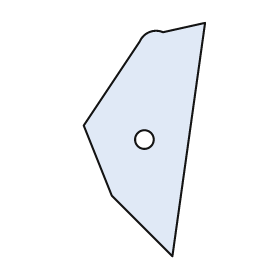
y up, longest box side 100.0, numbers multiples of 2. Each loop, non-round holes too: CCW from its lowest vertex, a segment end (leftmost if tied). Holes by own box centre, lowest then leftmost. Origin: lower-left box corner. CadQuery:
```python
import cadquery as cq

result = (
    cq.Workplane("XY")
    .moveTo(38.0, 0.0)
    .lineTo(52.0, 100.0)
    .lineTo(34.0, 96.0)
    .threePointArc((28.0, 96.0), (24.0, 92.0))
    .lineTo(0.0, 56.0)
    .lineTo(12.0, 26.0)
    .close()
    .moveTo(26.0, 50.0)
    .circle(4.0)
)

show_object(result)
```